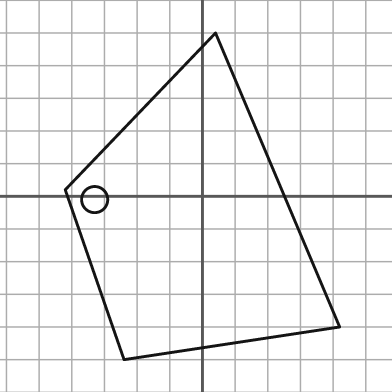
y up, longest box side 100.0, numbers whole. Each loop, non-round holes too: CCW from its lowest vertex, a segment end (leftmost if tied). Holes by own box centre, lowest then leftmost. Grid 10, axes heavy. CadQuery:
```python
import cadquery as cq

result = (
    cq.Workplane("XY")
    .moveTo(-24.0, -50.0)
    .lineTo(42.0, -40.0)
    .lineTo(4.0, 50.0)
    .lineTo(-42.0, 2.0)
    .close()
    .moveTo(-33.0, -1.0)
    .circle(4.0)
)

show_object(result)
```